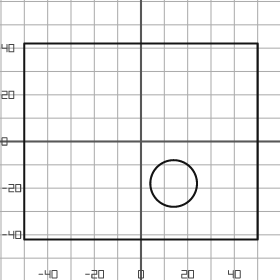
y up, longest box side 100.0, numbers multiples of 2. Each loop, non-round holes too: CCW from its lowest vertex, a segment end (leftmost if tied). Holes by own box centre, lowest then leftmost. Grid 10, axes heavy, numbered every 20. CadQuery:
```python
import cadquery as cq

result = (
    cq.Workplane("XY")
    .moveTo(-50.0, -42.0)
    .lineTo(50.0, -42.0)
    .lineTo(50.0, 42.0)
    .lineTo(-50.0, 42.0)
    .close()
    .moveTo(14.0, -18.0)
    .circle(10.0)
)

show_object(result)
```